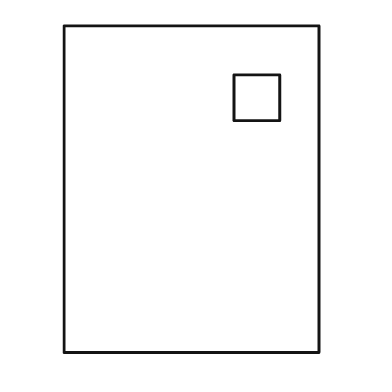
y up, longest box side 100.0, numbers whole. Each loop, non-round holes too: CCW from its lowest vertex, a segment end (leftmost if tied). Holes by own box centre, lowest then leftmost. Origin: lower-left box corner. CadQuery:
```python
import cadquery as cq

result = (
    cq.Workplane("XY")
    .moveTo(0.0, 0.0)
    .lineTo(78.0, 0.0)
    .lineTo(78.0, 100.0)
    .lineTo(0.0, 100.0)
    .close()
    .moveTo(52.0, 71.0)
    .lineTo(66.0, 71.0)
    .lineTo(66.0, 85.0)
    .lineTo(52.0, 85.0)
    .close()
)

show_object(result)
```